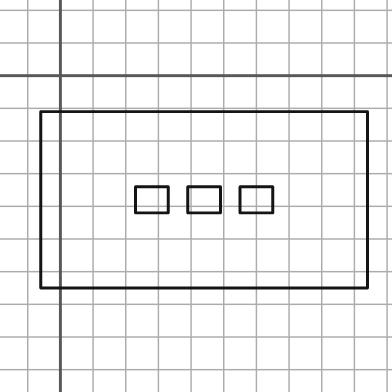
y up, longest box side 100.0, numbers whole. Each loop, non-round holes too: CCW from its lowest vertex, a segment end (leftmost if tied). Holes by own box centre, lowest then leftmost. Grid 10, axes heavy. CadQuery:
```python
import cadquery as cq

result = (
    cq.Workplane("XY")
    .moveTo(-6.0, -65.0)
    .lineTo(94.0, -65.0)
    .lineTo(94.0, -11.0)
    .lineTo(-6.0, -11.0)
    .close()
    .moveTo(23.0, -42.0)
    .lineTo(33.0, -42.0)
    .lineTo(33.0, -34.0)
    .lineTo(23.0, -34.0)
    .close()
    .moveTo(39.0, -42.0)
    .lineTo(49.0, -42.0)
    .lineTo(49.0, -34.0)
    .lineTo(39.0, -34.0)
    .close()
    .moveTo(55.0, -42.0)
    .lineTo(65.0, -42.0)
    .lineTo(65.0, -34.0)
    .lineTo(55.0, -34.0)
    .close()
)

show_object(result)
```